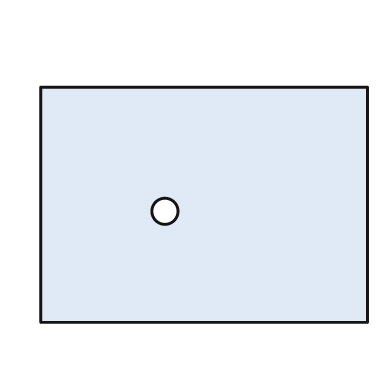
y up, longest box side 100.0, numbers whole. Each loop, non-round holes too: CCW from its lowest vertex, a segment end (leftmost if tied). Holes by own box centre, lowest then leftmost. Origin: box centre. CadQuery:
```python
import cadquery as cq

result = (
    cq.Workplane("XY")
    .moveTo(-50.0, -36.0)
    .lineTo(50.0, -36.0)
    .lineTo(50.0, 36.0)
    .lineTo(-50.0, 36.0)
    .close()
    .moveTo(-12.0, -2.0)
    .circle(4.0)
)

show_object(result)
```